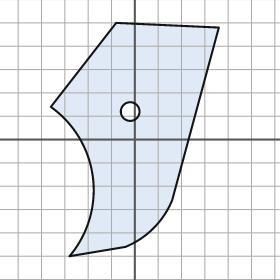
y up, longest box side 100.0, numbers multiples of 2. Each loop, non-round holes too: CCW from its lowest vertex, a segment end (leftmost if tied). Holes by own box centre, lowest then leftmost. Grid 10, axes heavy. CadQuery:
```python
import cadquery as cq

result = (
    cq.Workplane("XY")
    .moveTo(-28.0, -50.0)
    .lineTo(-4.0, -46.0)
    .threePointArc((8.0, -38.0), (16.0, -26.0))
    .lineTo(36.0, 48.0)
    .lineTo(-8.0, 50.0)
    .lineTo(-36.0, 14.0)
    .threePointArc((-18.0, -16.0), (-28.0, -50.0))
    .close()
    .moveTo(-2.0, 12.0)
    .circle(4.0)
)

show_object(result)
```